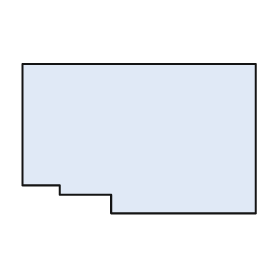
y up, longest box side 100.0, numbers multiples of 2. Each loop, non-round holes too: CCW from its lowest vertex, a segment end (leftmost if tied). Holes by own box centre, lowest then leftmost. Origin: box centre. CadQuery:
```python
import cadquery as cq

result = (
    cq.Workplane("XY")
    .moveTo(-12.0, -32.0)
    .lineTo(50.0, -32.0)
    .lineTo(50.0, 32.0)
    .lineTo(-50.0, 32.0)
    .lineTo(-50.0, -20.0)
    .lineTo(-34.0, -20.0)
    .lineTo(-34.0, -24.0)
    .lineTo(-12.0, -24.0)
    .close()
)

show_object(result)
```